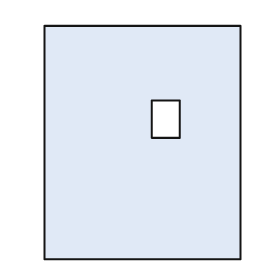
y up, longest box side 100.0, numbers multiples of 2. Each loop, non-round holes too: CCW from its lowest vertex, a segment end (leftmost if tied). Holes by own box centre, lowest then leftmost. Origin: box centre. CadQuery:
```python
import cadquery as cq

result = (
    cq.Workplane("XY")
    .moveTo(-42.0, -50.0)
    .lineTo(42.0, -50.0)
    .lineTo(42.0, 50.0)
    .lineTo(-42.0, 50.0)
    .close()
    .moveTo(4.0, 2.0)
    .lineTo(16.0, 2.0)
    .lineTo(16.0, 18.0)
    .lineTo(4.0, 18.0)
    .close()
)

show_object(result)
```